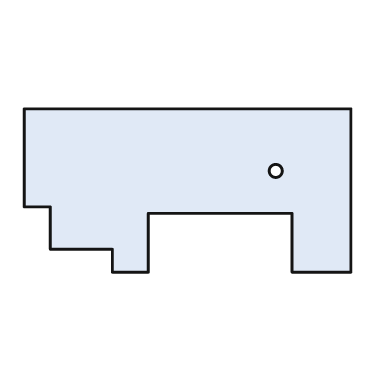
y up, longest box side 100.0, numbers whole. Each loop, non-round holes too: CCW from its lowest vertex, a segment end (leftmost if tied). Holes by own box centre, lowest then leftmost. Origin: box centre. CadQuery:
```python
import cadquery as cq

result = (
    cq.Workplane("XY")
    .moveTo(-23.0, -25.0)
    .lineTo(-12.0, -25.0)
    .lineTo(-12.0, -7.0)
    .lineTo(32.0, -7.0)
    .lineTo(32.0, -25.0)
    .lineTo(50.0, -25.0)
    .lineTo(50.0, 25.0)
    .lineTo(-50.0, 25.0)
    .lineTo(-50.0, -5.0)
    .lineTo(-42.0, -5.0)
    .lineTo(-42.0, -18.0)
    .lineTo(-23.0, -18.0)
    .close()
    .moveTo(27.0, 6.0)
    .circle(2.0)
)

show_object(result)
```